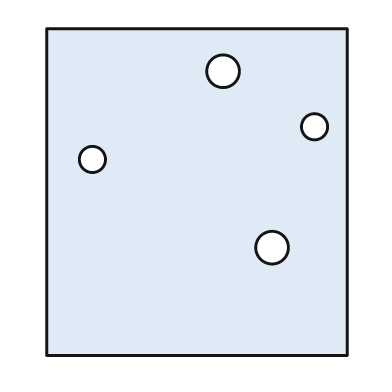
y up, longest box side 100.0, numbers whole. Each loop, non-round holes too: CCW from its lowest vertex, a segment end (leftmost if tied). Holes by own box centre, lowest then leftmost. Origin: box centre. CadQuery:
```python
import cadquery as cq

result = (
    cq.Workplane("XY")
    .moveTo(-46.0, -50.0)
    .lineTo(46.0, -50.0)
    .lineTo(46.0, 50.0)
    .lineTo(-46.0, 50.0)
    .close()
    .moveTo(23.0, -17.0)
    .circle(5.0)
    .moveTo(-32.0, 10.0)
    .circle(4.0)
    .moveTo(36.0, 20.0)
    .circle(4.0)
    .moveTo(8.0, 37.0)
    .circle(5.0)
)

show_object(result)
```